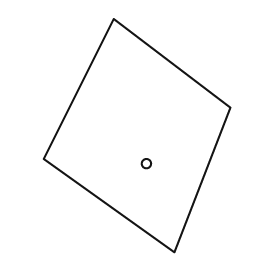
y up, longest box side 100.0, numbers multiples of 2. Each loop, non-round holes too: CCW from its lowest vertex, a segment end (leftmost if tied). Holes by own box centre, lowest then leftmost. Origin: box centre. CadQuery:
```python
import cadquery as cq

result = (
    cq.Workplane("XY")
    .moveTo(16.0, -50.0)
    .lineTo(40.0, 12.0)
    .lineTo(-10.0, 50.0)
    .lineTo(-40.0, -10.0)
    .close()
    .moveTo(4.0, -12.0)
    .circle(2.0)
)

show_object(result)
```